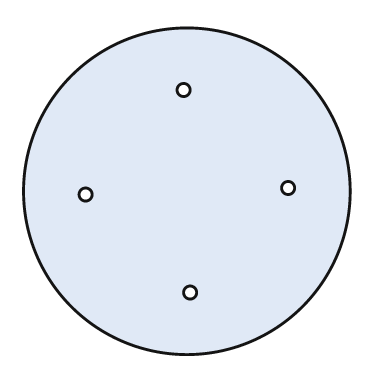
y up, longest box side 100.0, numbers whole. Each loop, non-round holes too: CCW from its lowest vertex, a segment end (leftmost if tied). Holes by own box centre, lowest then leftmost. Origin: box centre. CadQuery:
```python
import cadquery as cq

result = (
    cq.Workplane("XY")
    .moveTo(0.0, 0.0)
    .circle(50.0)
    .moveTo(1.0, -31.0)
    .circle(2.0)
    .moveTo(-31.0, -1.0)
    .circle(2.0)
    .moveTo(31.0, 1.0)
    .circle(2.0)
    .moveTo(-1.0, 31.0)
    .circle(2.0)
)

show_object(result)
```